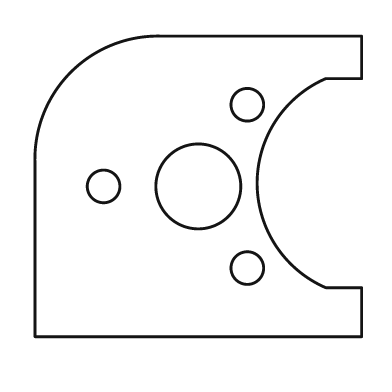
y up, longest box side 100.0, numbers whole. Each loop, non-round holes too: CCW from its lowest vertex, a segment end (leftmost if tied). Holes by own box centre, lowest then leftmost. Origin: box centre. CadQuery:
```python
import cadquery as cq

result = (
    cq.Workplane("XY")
    .moveTo(-50.0, -46.0)
    .lineTo(50.0, -46.0)
    .lineTo(50.0, -31.0)
    .lineTo(39.0, -31.0)
    .threePointArc((18.0, 1.0), (39.0, 33.0))
    .lineTo(50.0, 33.0)
    .lineTo(50.0, 46.0)
    .lineTo(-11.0, 46.0)
    .threePointArc((-39.0, 35.0), (-50.0, 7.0))
    .close()
    .moveTo(15.0, -25.0)
    .circle(5.0)
    .moveTo(-29.0, 0.0)
    .circle(5.0)
    .moveTo(0.0, 0.0)
    .circle(13.0)
    .moveTo(15.0, 25.0)
    .circle(5.0)
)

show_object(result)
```